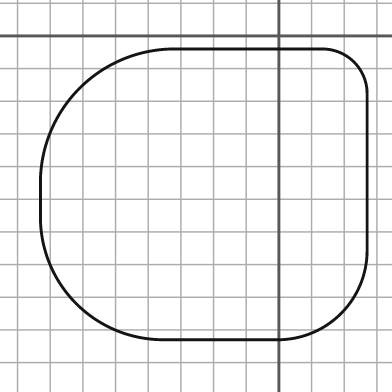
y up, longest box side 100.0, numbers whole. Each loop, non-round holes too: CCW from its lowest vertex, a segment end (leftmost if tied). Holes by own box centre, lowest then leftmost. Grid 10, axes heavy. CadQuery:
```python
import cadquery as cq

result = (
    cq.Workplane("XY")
    .moveTo(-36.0, -93.0)
    .lineTo(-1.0, -93.0)
    .threePointArc((19.0, -85.0), (27.0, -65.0))
    .lineTo(27.0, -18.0)
    .threePointArc((23.0, -8.0), (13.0, -4.0))
    .lineTo(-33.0, -4.0)
    .threePointArc((-61.0, -16.0), (-73.0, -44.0))
    .lineTo(-73.0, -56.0)
    .threePointArc((-62.0, -82.0), (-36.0, -93.0))
    .close()
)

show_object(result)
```